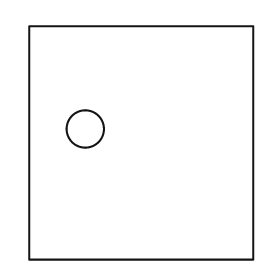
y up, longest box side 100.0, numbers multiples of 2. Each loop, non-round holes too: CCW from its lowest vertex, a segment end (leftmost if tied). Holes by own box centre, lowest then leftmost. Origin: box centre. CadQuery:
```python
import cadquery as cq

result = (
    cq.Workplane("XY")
    .moveTo(-48.0, -50.0)
    .lineTo(48.0, -50.0)
    .lineTo(48.0, 50.0)
    .lineTo(-48.0, 50.0)
    .close()
    .moveTo(-24.0, 6.0)
    .circle(8.0)
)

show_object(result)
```